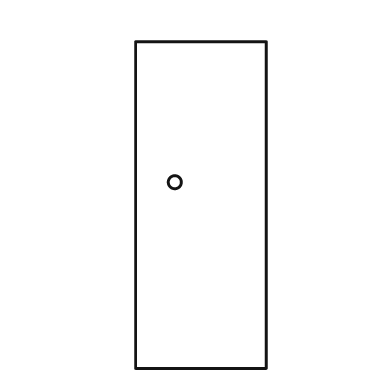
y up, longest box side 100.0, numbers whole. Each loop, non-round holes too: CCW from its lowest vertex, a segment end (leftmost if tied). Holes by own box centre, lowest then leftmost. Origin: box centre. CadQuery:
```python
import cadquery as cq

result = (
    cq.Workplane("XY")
    .moveTo(-20.0, -50.0)
    .lineTo(20.0, -50.0)
    .lineTo(20.0, 50.0)
    .lineTo(-20.0, 50.0)
    .close()
    .moveTo(-8.0, 7.0)
    .circle(2.0)
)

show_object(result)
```